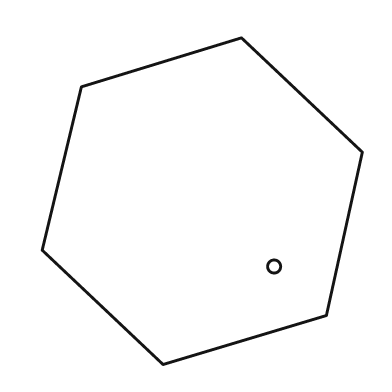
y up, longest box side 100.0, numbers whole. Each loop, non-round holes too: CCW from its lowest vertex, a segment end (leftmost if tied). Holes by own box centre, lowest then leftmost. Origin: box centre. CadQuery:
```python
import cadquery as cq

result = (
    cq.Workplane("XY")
    .moveTo(-12.0, -50.0)
    .lineTo(38.0, -35.0)
    .lineTo(49.0, 15.0)
    .lineTo(12.0, 50.0)
    .lineTo(-37.0, 35.0)
    .lineTo(-49.0, -15.0)
    .close()
    .moveTo(22.0, -20.0)
    .circle(2.0)
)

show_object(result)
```